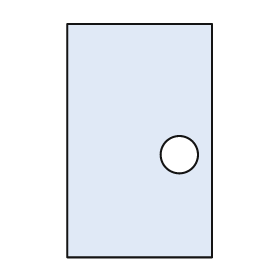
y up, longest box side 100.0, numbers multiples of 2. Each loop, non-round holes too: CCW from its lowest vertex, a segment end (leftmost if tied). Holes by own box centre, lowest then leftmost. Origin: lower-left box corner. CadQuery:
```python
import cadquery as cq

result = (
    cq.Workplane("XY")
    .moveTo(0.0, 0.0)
    .lineTo(62.0, 0.0)
    .lineTo(62.0, 100.0)
    .lineTo(0.0, 100.0)
    .close()
    .moveTo(48.0, 44.0)
    .circle(8.0)
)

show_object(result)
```